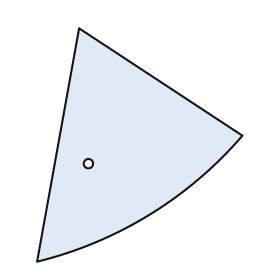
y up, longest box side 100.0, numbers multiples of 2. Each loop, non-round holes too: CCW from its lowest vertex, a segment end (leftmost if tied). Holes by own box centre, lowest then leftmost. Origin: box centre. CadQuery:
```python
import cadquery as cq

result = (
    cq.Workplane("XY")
    .moveTo(-44.0, -50.0)
    .threePointArc((4.0, -30.0), (44.0, 4.0))
    .lineTo(-26.0, 50.0)
    .close()
    .moveTo(-22.0, -8.0)
    .circle(2.0)
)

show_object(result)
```